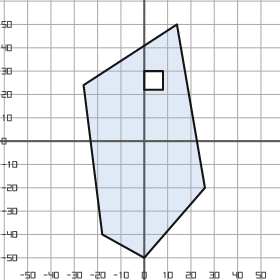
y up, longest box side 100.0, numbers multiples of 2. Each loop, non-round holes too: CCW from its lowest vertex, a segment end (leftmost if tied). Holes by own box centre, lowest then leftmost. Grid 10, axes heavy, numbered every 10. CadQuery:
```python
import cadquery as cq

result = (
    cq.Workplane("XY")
    .moveTo(0.0, -50.0)
    .lineTo(26.0, -20.0)
    .lineTo(14.0, 50.0)
    .lineTo(-26.0, 24.0)
    .lineTo(-18.0, -40.0)
    .close()
    .moveTo(0.0, 22.0)
    .lineTo(8.0, 22.0)
    .lineTo(8.0, 30.0)
    .lineTo(0.0, 30.0)
    .close()
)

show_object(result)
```